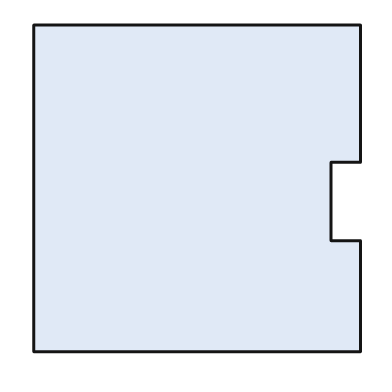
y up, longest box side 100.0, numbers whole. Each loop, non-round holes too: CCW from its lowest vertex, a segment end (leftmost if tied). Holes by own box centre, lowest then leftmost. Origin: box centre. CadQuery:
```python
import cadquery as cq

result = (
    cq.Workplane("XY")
    .moveTo(-50.0, -50.0)
    .lineTo(50.0, -50.0)
    .lineTo(50.0, -16.0)
    .lineTo(41.0, -16.0)
    .lineTo(41.0, 8.0)
    .lineTo(50.0, 8.0)
    .lineTo(50.0, 50.0)
    .lineTo(-50.0, 50.0)
    .close()
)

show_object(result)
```